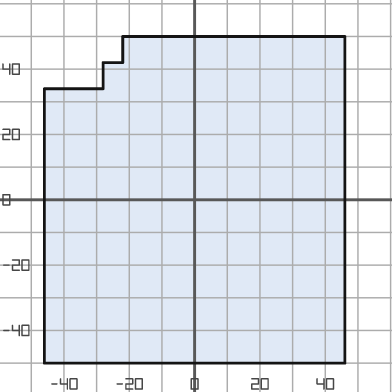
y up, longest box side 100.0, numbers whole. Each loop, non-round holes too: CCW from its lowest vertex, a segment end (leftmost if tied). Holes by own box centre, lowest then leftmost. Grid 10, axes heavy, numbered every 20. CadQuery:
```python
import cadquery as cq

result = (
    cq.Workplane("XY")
    .moveTo(-46.0, -50.0)
    .lineTo(46.0, -50.0)
    .lineTo(46.0, 50.0)
    .lineTo(-22.0, 50.0)
    .lineTo(-22.0, 42.0)
    .lineTo(-28.0, 42.0)
    .lineTo(-28.0, 34.0)
    .lineTo(-46.0, 34.0)
    .close()
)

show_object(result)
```